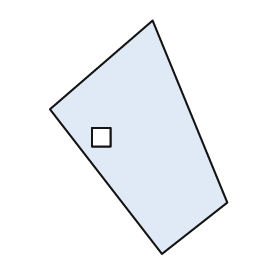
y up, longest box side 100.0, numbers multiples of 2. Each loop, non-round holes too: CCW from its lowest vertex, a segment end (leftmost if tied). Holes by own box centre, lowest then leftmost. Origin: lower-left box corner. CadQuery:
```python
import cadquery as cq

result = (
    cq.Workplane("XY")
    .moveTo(48.0, 0.0)
    .lineTo(76.0, 22.0)
    .lineTo(44.0, 100.0)
    .lineTo(0.0, 62.0)
    .close()
    .moveTo(18.0, 46.0)
    .lineTo(26.0, 46.0)
    .lineTo(26.0, 54.0)
    .lineTo(18.0, 54.0)
    .close()
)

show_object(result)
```